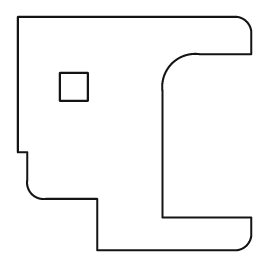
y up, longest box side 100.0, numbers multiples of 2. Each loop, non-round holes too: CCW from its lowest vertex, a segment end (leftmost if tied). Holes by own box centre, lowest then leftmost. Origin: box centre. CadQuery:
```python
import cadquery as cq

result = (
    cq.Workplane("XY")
    .moveTo(-16.0, -50.0)
    .lineTo(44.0, -50.0)
    .threePointArc((48.0, -48.0), (50.0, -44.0))
    .lineTo(50.0, -36.0)
    .lineTo(12.0, -36.0)
    .lineTo(12.0, 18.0)
    .threePointArc((16.0, 30.0), (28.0, 34.0))
    .lineTo(50.0, 34.0)
    .lineTo(50.0, 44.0)
    .threePointArc((48.0, 48.0), (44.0, 50.0))
    .lineTo(-50.0, 50.0)
    .lineTo(-50.0, -8.0)
    .lineTo(-46.0, -8.0)
    .lineTo(-46.0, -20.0)
    .threePointArc((-44.0, -26.0), (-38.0, -28.0))
    .lineTo(-16.0, -28.0)
    .close()
    .moveTo(-32.0, 14.0)
    .lineTo(-20.0, 14.0)
    .lineTo(-20.0, 26.0)
    .lineTo(-32.0, 26.0)
    .close()
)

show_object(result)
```